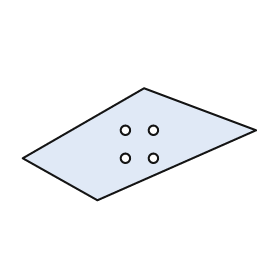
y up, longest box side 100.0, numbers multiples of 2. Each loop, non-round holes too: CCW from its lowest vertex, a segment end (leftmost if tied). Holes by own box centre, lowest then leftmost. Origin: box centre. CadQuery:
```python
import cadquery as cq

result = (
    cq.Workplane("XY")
    .moveTo(-18.0, -24.0)
    .lineTo(50.0, 6.0)
    .lineTo(2.0, 24.0)
    .lineTo(-50.0, -6.0)
    .close()
    .moveTo(-6.0, -6.0)
    .circle(2.0)
    .moveTo(6.0, -6.0)
    .circle(2.0)
    .moveTo(-6.0, 6.0)
    .circle(2.0)
    .moveTo(6.0, 6.0)
    .circle(2.0)
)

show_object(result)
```